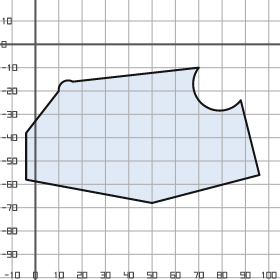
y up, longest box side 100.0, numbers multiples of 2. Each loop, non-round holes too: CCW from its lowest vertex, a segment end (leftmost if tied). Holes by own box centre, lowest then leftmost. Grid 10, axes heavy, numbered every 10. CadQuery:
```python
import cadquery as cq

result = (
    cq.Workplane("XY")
    .moveTo(50.0, -68.0)
    .lineTo(96.0, -56.0)
    .lineTo(88.0, -24.0)
    .threePointArc((72.0, -26.0), (70.0, -10.0))
    .lineTo(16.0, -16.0)
    .threePointArc((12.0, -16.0), (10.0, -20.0))
    .lineTo(-4.0, -38.0)
    .lineTo(-4.0, -58.0)
    .close()
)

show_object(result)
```